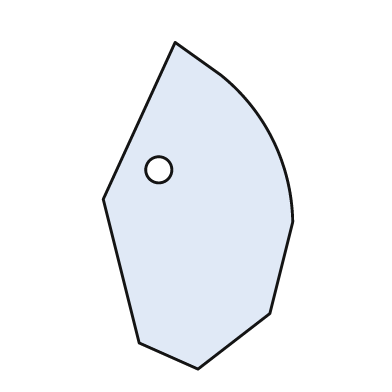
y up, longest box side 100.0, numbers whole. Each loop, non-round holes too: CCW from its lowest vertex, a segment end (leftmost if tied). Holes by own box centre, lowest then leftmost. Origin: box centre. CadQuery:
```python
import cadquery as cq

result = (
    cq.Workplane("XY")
    .moveTo(0.0, -50.0)
    .lineTo(22.0, -33.0)
    .lineTo(29.0, -5.0)
    .threePointArc((23.0, 20.0), (7.0, 40.0))
    .lineTo(-7.0, 50.0)
    .lineTo(-29.0, 2.0)
    .lineTo(-18.0, -42.0)
    .close()
    .moveTo(-12.0, 11.0)
    .circle(4.0)
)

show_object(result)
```